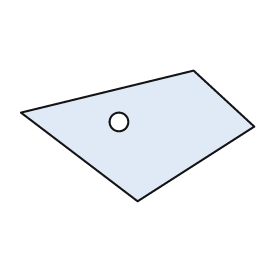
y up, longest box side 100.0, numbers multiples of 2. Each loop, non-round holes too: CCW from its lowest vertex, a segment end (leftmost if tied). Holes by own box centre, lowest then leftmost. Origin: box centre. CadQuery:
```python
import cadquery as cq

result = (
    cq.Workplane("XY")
    .moveTo(0.0, -28.0)
    .lineTo(50.0, 4.0)
    .lineTo(24.0, 28.0)
    .lineTo(-50.0, 10.0)
    .close()
    .moveTo(-8.0, 6.0)
    .circle(4.0)
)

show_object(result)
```